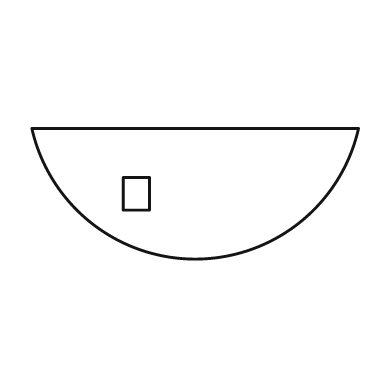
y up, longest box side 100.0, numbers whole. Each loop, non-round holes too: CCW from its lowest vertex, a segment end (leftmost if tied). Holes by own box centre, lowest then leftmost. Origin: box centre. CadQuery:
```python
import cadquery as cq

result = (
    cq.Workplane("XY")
    .moveTo(-50.0, 20.0)
    .threePointArc((0.0, -20.0), (50.0, 20.0))
    .close()
    .moveTo(-22.0, -5.0)
    .lineTo(-14.0, -5.0)
    .lineTo(-14.0, 5.0)
    .lineTo(-22.0, 5.0)
    .close()
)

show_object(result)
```